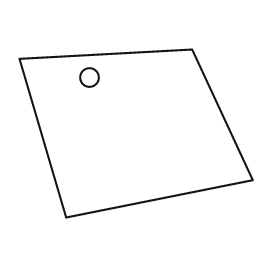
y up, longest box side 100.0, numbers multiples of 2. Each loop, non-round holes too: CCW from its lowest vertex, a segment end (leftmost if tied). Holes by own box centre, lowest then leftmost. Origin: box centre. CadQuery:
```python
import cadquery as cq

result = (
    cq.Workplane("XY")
    .moveTo(-30.0, -36.0)
    .lineTo(50.0, -20.0)
    .lineTo(24.0, 36.0)
    .lineTo(-50.0, 32.0)
    .close()
    .moveTo(-20.0, 24.0)
    .circle(4.0)
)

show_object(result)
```